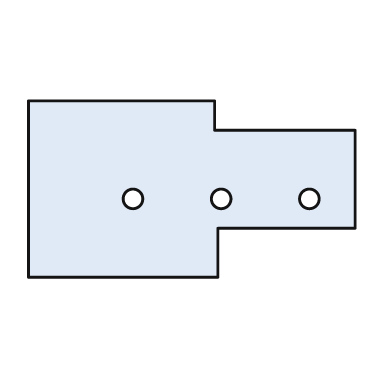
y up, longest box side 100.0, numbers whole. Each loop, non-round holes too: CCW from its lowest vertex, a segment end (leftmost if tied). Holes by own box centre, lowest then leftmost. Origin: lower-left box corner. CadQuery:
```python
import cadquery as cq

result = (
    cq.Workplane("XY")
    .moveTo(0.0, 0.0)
    .lineTo(58.0, 0.0)
    .lineTo(58.0, 15.0)
    .lineTo(100.0, 15.0)
    .lineTo(100.0, 45.0)
    .lineTo(57.0, 45.0)
    .lineTo(57.0, 54.0)
    .lineTo(0.0, 54.0)
    .close()
    .moveTo(32.0, 24.0)
    .circle(3.0)
    .moveTo(59.0, 24.0)
    .circle(3.0)
    .moveTo(86.0, 24.0)
    .circle(3.0)
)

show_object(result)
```